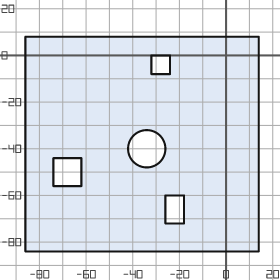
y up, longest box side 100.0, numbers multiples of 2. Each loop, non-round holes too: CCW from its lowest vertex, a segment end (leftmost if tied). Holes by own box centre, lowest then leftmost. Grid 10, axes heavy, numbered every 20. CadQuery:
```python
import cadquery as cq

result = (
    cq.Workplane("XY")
    .moveTo(-86.0, -84.0)
    .lineTo(14.0, -84.0)
    .lineTo(14.0, 8.0)
    .lineTo(-86.0, 8.0)
    .close()
    .moveTo(-26.0, -72.0)
    .lineTo(-18.0, -72.0)
    .lineTo(-18.0, -60.0)
    .lineTo(-26.0, -60.0)
    .close()
    .moveTo(-74.0, -56.0)
    .lineTo(-62.0, -56.0)
    .lineTo(-62.0, -44.0)
    .lineTo(-74.0, -44.0)
    .close()
    .moveTo(-34.0, -40.0)
    .circle(8.0)
    .moveTo(-32.0, -8.0)
    .lineTo(-24.0, -8.0)
    .lineTo(-24.0, 0.0)
    .lineTo(-32.0, 0.0)
    .close()
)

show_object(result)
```